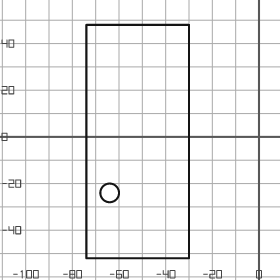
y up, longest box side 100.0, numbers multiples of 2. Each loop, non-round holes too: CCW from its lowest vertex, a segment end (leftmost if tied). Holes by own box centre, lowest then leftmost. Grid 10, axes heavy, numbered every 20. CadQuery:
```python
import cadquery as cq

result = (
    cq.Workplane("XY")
    .moveTo(-74.0, -52.0)
    .lineTo(-30.0, -52.0)
    .lineTo(-30.0, 48.0)
    .lineTo(-74.0, 48.0)
    .close()
    .moveTo(-64.0, -24.0)
    .circle(4.0)
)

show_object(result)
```